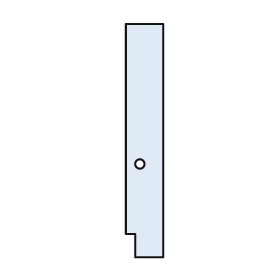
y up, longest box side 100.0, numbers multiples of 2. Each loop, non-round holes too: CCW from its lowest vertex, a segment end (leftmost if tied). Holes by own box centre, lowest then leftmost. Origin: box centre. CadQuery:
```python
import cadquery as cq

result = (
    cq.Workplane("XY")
    .moveTo(-4.0, -50.0)
    .lineTo(8.0, -50.0)
    .lineTo(8.0, 50.0)
    .lineTo(-8.0, 50.0)
    .lineTo(-8.0, -40.0)
    .lineTo(-4.0, -40.0)
    .close()
    .moveTo(-2.0, -10.0)
    .circle(2.0)
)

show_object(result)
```